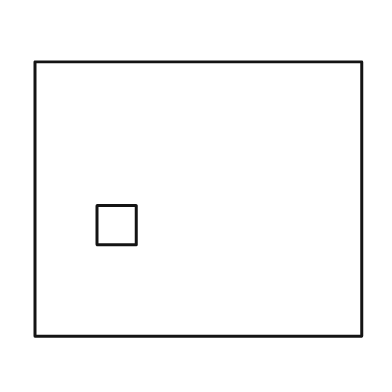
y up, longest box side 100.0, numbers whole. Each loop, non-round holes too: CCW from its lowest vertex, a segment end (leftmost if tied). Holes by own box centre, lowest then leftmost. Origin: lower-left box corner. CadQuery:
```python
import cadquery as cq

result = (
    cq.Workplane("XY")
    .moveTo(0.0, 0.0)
    .lineTo(100.0, 0.0)
    .lineTo(100.0, 84.0)
    .lineTo(0.0, 84.0)
    .close()
    .moveTo(19.0, 28.0)
    .lineTo(31.0, 28.0)
    .lineTo(31.0, 40.0)
    .lineTo(19.0, 40.0)
    .close()
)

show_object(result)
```